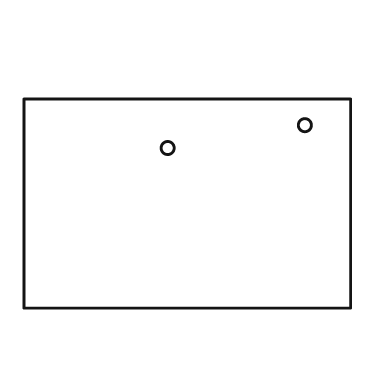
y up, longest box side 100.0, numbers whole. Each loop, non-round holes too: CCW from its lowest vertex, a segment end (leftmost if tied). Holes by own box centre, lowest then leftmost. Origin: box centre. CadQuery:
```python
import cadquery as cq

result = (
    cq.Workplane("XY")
    .moveTo(-50.0, -32.0)
    .lineTo(50.0, -32.0)
    .lineTo(50.0, 32.0)
    .lineTo(-50.0, 32.0)
    .close()
    .moveTo(-6.0, 17.0)
    .circle(2.0)
    .moveTo(36.0, 24.0)
    .circle(2.0)
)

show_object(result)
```